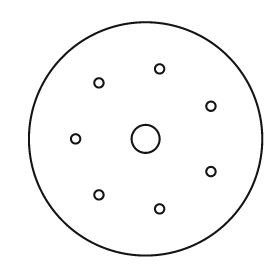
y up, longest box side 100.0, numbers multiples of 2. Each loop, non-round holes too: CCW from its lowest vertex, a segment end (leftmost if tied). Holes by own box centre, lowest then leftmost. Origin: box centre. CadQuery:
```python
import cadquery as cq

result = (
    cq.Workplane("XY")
    .moveTo(0.0, 0.0)
    .circle(50.0)
    .moveTo(6.0, -30.0)
    .circle(2.0)
    .moveTo(-20.0, -24.0)
    .circle(2.0)
    .moveTo(28.0, -14.0)
    .circle(2.0)
    .moveTo(-30.0, 0.0)
    .circle(2.0)
    .moveTo(0.0, 0.0)
    .circle(6.0)
    .moveTo(28.0, 14.0)
    .circle(2.0)
    .moveTo(-20.0, 24.0)
    .circle(2.0)
    .moveTo(6.0, 30.0)
    .circle(2.0)
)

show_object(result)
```